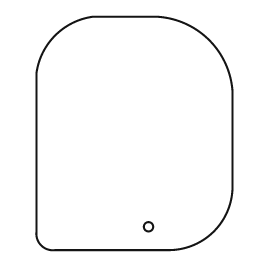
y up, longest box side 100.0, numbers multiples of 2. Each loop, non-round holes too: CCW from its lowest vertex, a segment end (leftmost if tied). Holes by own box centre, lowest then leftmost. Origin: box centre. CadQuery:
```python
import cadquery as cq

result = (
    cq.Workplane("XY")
    .moveTo(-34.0, -50.0)
    .lineTo(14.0, -50.0)
    .threePointArc((34.0, -42.0), (42.0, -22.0))
    .lineTo(42.0, 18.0)
    .threePointArc((32.0, 40.0), (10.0, 50.0))
    .lineTo(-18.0, 50.0)
    .threePointArc((-34.0, 42.0), (-42.0, 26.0))
    .lineTo(-42.0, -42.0)
    .threePointArc((-40.0, -48.0), (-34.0, -50.0))
    .close()
    .moveTo(6.0, -40.0)
    .circle(2.0)
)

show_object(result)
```